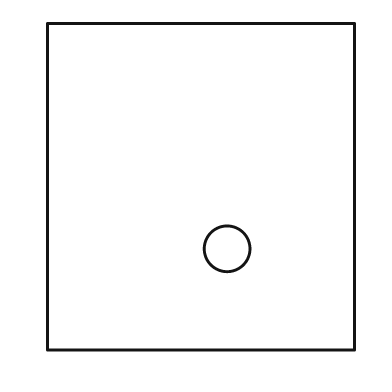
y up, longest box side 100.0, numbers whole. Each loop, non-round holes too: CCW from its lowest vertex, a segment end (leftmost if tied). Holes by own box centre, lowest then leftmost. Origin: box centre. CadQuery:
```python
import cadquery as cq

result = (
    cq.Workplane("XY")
    .moveTo(-47.0, -50.0)
    .lineTo(47.0, -50.0)
    .lineTo(47.0, 50.0)
    .lineTo(-47.0, 50.0)
    .close()
    .moveTo(8.0, -19.0)
    .circle(7.0)
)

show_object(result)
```